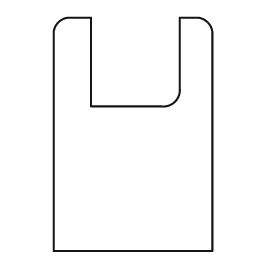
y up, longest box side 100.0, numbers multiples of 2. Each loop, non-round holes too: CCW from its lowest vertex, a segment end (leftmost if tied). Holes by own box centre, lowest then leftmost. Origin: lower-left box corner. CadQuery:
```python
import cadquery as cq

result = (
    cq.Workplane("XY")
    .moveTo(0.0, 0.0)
    .lineTo(68.0, 0.0)
    .lineTo(68.0, 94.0)
    .threePointArc((66.0, 98.0), (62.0, 100.0))
    .lineTo(54.0, 100.0)
    .lineTo(54.0, 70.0)
    .threePointArc((52.0, 64.0), (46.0, 62.0))
    .lineTo(16.0, 62.0)
    .lineTo(16.0, 100.0)
    .lineTo(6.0, 100.0)
    .threePointArc((2.0, 98.0), (0.0, 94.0))
    .close()
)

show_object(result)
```